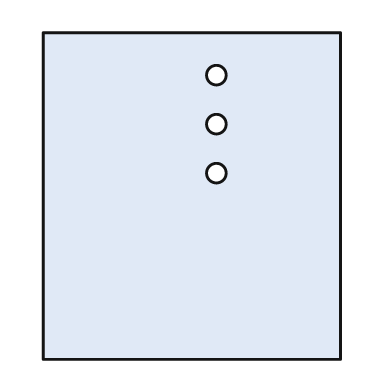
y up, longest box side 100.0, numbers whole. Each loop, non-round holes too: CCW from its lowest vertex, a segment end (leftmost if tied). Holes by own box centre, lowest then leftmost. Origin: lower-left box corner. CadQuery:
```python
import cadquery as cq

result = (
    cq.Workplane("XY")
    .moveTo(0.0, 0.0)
    .lineTo(91.0, 0.0)
    .lineTo(91.0, 100.0)
    .lineTo(0.0, 100.0)
    .close()
    .moveTo(53.0, 57.0)
    .circle(3.0)
    .moveTo(53.0, 72.0)
    .circle(3.0)
    .moveTo(53.0, 87.0)
    .circle(3.0)
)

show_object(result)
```